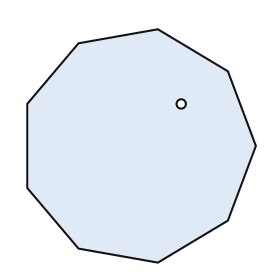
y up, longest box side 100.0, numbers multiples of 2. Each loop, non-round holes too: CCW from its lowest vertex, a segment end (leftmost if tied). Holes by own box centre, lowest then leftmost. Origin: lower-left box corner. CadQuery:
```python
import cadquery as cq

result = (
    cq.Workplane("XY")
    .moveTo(56.0, 0.0)
    .lineTo(86.0, 18.0)
    .lineTo(98.0, 50.0)
    .lineTo(86.0, 82.0)
    .lineTo(56.0, 100.0)
    .lineTo(22.0, 94.0)
    .lineTo(0.0, 68.0)
    .lineTo(0.0, 32.0)
    .lineTo(22.0, 6.0)
    .close()
    .moveTo(66.0, 68.0)
    .circle(2.0)
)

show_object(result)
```